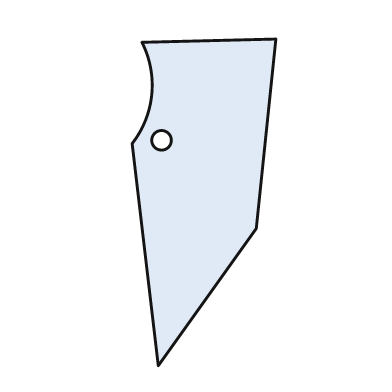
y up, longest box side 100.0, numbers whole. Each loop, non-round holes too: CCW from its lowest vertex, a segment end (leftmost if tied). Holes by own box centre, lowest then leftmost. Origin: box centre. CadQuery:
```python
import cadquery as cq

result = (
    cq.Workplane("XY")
    .moveTo(-14.0, -50.0)
    .lineTo(16.0, -8.0)
    .lineTo(22.0, 50.0)
    .lineTo(-19.0, 49.0)
    .threePointArc((-16.0, 33.0), (-22.0, 18.0))
    .close()
    .moveTo(-13.0, 19.0)
    .circle(3.0)
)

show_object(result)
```